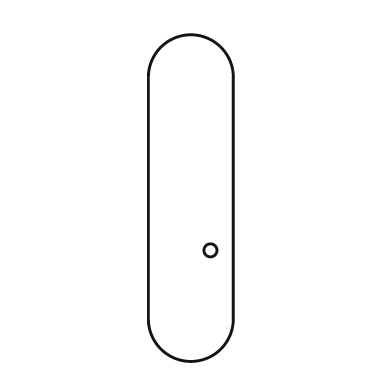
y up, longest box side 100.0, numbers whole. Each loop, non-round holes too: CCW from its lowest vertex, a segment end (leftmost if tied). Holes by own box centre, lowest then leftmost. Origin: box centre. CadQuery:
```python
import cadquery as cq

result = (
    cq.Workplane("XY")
    .moveTo(-13.0, -37.0)
    .threePointArc((0.0, -50.0), (13.0, -37.0))
    .lineTo(13.0, 37.0)
    .threePointArc((0.0, 50.0), (-13.0, 37.0))
    .close()
    .moveTo(6.0, -16.0)
    .circle(2.0)
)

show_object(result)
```